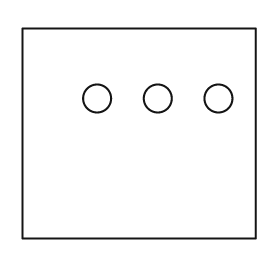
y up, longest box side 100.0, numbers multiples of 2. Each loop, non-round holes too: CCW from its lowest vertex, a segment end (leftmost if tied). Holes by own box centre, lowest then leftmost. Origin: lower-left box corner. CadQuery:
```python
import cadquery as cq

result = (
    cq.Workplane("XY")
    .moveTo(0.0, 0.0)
    .lineTo(100.0, 0.0)
    .lineTo(100.0, 90.0)
    .lineTo(0.0, 90.0)
    .close()
    .moveTo(32.0, 60.0)
    .circle(6.0)
    .moveTo(58.0, 60.0)
    .circle(6.0)
    .moveTo(84.0, 60.0)
    .circle(6.0)
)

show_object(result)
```